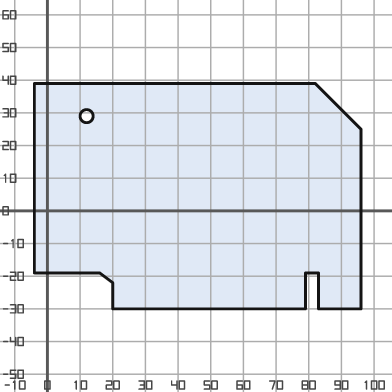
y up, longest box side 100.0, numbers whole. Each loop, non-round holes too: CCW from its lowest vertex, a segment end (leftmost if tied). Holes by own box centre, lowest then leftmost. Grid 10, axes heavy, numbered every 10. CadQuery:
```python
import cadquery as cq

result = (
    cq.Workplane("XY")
    .moveTo(20.0, -30.0)
    .lineTo(79.0, -30.0)
    .lineTo(79.0, -19.0)
    .lineTo(83.0, -19.0)
    .lineTo(83.0, -30.0)
    .lineTo(96.0, -30.0)
    .lineTo(96.0, 25.0)
    .lineTo(82.0, 39.0)
    .lineTo(-4.0, 39.0)
    .lineTo(-4.0, -19.0)
    .lineTo(16.0, -19.0)
    .lineTo(20.0, -22.0)
    .close()
    .moveTo(12.0, 29.0)
    .circle(2.0)
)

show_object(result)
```